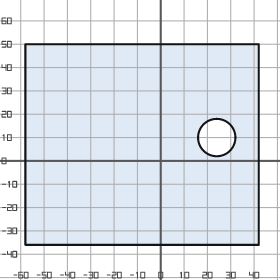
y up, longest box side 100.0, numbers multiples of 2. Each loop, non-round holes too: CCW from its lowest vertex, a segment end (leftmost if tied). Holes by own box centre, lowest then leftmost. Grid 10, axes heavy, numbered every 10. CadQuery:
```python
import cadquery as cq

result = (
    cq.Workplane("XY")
    .moveTo(-58.0, -36.0)
    .lineTo(42.0, -36.0)
    .lineTo(42.0, 50.0)
    .lineTo(-58.0, 50.0)
    .close()
    .moveTo(24.0, 10.0)
    .circle(8.0)
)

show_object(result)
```